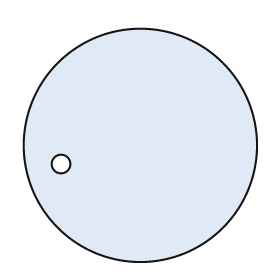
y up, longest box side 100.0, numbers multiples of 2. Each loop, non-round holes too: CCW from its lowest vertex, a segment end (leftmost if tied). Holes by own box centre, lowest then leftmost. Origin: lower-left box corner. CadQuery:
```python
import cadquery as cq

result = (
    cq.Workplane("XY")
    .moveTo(50.0, 50.0)
    .circle(50.0)
    .moveTo(16.0, 42.0)
    .circle(4.0)
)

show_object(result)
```